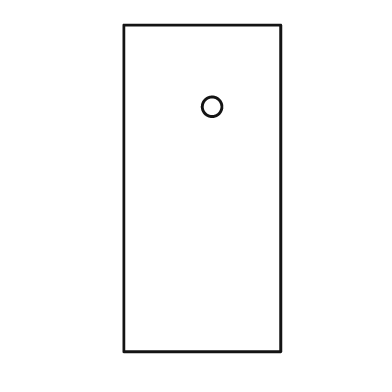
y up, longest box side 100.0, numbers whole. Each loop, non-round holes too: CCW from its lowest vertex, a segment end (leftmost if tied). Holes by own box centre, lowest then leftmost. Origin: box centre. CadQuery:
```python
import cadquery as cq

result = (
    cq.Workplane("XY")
    .moveTo(-24.0, -50.0)
    .lineTo(24.0, -50.0)
    .lineTo(24.0, 50.0)
    .lineTo(-24.0, 50.0)
    .close()
    .moveTo(3.0, 25.0)
    .circle(3.0)
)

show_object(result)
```